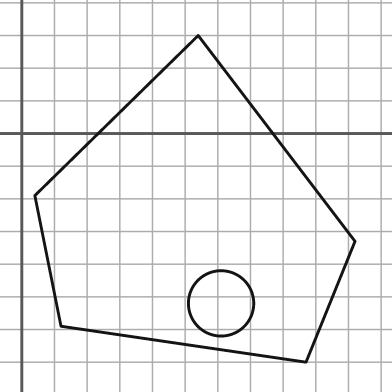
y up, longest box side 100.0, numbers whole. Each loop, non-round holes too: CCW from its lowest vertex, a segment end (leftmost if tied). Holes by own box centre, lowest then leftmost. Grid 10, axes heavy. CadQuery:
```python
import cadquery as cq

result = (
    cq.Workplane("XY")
    .moveTo(87.0, -70.0)
    .lineTo(102.0, -33.0)
    .lineTo(54.0, 30.0)
    .lineTo(4.0, -19.0)
    .lineTo(12.0, -59.0)
    .close()
    .moveTo(61.0, -52.0)
    .circle(10.0)
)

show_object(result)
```